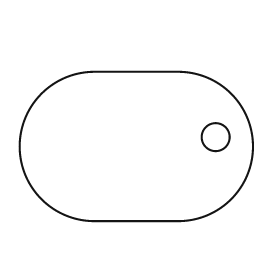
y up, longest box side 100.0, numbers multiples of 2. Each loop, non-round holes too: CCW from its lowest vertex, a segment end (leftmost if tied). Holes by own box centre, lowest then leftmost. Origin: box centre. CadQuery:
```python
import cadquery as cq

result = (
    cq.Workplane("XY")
    .moveTo(-18.0, -32.0)
    .lineTo(18.0, -32.0)
    .threePointArc((50.0, 0.0), (18.0, 32.0))
    .lineTo(-18.0, 32.0)
    .threePointArc((-50.0, 0.0), (-18.0, -32.0))
    .close()
    .moveTo(34.0, 4.0)
    .circle(6.0)
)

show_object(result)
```